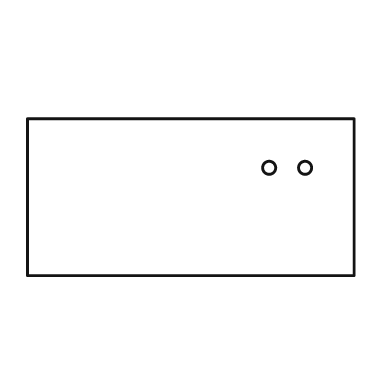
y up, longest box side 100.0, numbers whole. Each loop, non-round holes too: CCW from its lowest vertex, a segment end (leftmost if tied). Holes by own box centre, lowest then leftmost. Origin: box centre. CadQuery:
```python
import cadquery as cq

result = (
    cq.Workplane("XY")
    .moveTo(-50.0, -24.0)
    .lineTo(50.0, -24.0)
    .lineTo(50.0, 24.0)
    .lineTo(-50.0, 24.0)
    .close()
    .moveTo(24.0, 9.0)
    .circle(2.0)
    .moveTo(35.0, 9.0)
    .circle(2.0)
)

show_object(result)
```